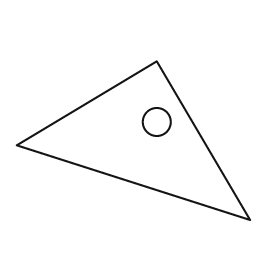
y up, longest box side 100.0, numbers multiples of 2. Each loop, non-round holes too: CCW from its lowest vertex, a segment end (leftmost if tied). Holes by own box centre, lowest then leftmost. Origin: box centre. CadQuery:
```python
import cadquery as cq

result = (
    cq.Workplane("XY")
    .moveTo(50.0, -34.0)
    .lineTo(10.0, 34.0)
    .lineTo(-50.0, -2.0)
    .close()
    .moveTo(10.0, 8.0)
    .circle(6.0)
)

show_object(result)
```